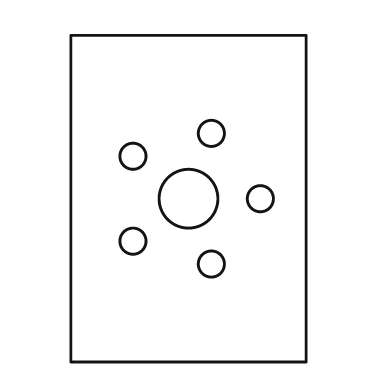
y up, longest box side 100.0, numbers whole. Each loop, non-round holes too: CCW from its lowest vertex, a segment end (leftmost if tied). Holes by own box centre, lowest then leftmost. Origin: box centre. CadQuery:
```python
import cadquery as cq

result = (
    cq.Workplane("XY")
    .moveTo(-36.0, -50.0)
    .lineTo(36.0, -50.0)
    .lineTo(36.0, 50.0)
    .lineTo(-36.0, 50.0)
    .close()
    .moveTo(7.0, -20.0)
    .circle(4.0)
    .moveTo(-17.0, -13.0)
    .circle(4.0)
    .moveTo(0.0, 0.0)
    .circle(9.0)
    .moveTo(22.0, 0.0)
    .circle(4.0)
    .moveTo(-17.0, 13.0)
    .circle(4.0)
    .moveTo(7.0, 20.0)
    .circle(4.0)
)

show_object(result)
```